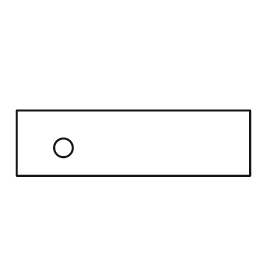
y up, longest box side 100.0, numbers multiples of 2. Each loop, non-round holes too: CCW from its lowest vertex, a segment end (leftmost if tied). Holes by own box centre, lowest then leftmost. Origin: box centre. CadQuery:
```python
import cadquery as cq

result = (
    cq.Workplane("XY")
    .moveTo(-50.0, -14.0)
    .lineTo(50.0, -14.0)
    .lineTo(50.0, 14.0)
    .lineTo(-50.0, 14.0)
    .close()
    .moveTo(-30.0, -2.0)
    .circle(4.0)
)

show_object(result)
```